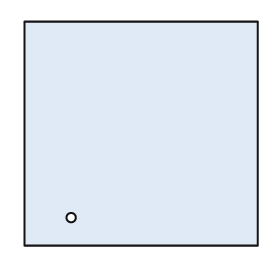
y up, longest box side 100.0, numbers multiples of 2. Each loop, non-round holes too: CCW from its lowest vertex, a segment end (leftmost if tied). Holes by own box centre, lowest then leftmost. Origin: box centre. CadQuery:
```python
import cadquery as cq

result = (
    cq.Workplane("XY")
    .moveTo(-50.0, -48.0)
    .lineTo(50.0, -48.0)
    .lineTo(50.0, 48.0)
    .lineTo(-50.0, 48.0)
    .close()
    .moveTo(-30.0, -36.0)
    .circle(2.0)
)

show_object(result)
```